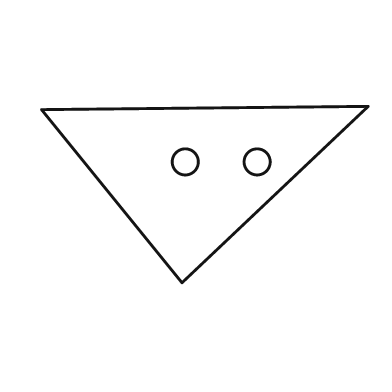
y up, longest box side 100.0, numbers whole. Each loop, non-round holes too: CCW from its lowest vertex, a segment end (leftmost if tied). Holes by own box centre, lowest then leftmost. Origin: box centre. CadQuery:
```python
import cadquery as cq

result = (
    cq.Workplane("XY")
    .moveTo(-7.0, -27.0)
    .lineTo(50.0, 27.0)
    .lineTo(-50.0, 26.0)
    .close()
    .moveTo(-6.0, 10.0)
    .circle(4.0)
    .moveTo(16.0, 10.0)
    .circle(4.0)
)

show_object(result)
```